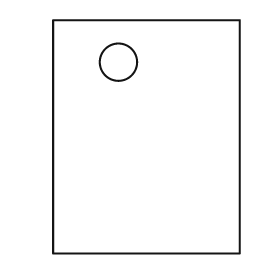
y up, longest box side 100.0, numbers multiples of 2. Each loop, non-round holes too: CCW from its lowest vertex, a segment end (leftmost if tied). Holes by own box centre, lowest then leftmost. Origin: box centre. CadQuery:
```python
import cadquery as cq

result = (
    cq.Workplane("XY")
    .moveTo(-40.0, -50.0)
    .lineTo(40.0, -50.0)
    .lineTo(40.0, 50.0)
    .lineTo(-40.0, 50.0)
    .close()
    .moveTo(-12.0, 32.0)
    .circle(8.0)
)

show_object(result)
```